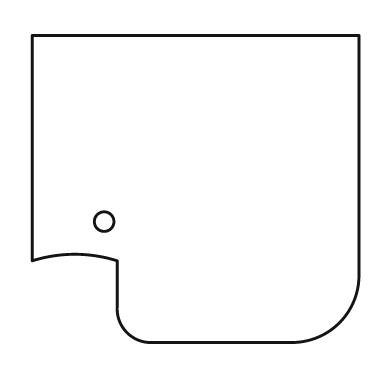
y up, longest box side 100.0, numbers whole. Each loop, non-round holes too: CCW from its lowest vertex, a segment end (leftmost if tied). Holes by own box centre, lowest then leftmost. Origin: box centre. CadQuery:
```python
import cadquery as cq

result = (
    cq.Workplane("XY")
    .moveTo(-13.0, -47.0)
    .lineTo(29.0, -47.0)
    .threePointArc((44.0, -41.0), (50.0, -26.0))
    .lineTo(50.0, 47.0)
    .lineTo(-50.0, 47.0)
    .lineTo(-50.0, -22.0)
    .threePointArc((-37.0, -20.0), (-24.0, -22.0))
    .lineTo(-24.0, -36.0)
    .threePointArc((-21.0, -44.0), (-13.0, -47.0))
    .close()
    .moveTo(-28.0, -10.0)
    .circle(3.0)
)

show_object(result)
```